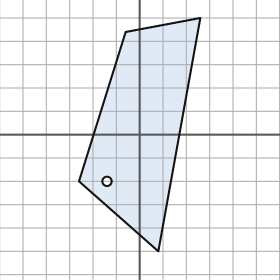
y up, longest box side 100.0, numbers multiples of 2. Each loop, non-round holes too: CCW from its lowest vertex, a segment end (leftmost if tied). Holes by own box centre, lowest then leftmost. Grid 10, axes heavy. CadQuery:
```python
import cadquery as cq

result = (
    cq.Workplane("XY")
    .moveTo(8.0, -50.0)
    .lineTo(26.0, 50.0)
    .lineTo(-6.0, 44.0)
    .lineTo(-26.0, -20.0)
    .close()
    .moveTo(-14.0, -20.0)
    .circle(2.0)
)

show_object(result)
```